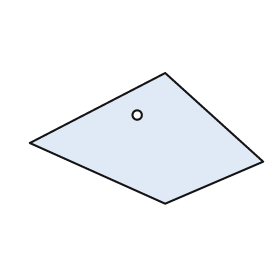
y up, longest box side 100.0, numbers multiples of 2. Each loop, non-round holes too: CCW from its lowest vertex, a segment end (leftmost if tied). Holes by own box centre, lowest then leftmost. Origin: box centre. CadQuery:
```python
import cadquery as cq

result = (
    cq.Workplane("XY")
    .moveTo(8.0, -28.0)
    .lineTo(50.0, -10.0)
    .lineTo(8.0, 28.0)
    .lineTo(-50.0, -2.0)
    .close()
    .moveTo(-4.0, 10.0)
    .circle(2.0)
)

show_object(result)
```